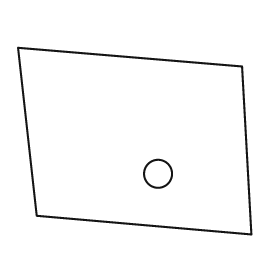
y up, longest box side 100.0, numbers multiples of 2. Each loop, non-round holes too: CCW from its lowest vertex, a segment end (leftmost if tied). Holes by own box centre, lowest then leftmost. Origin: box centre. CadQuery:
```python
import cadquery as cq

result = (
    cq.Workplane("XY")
    .moveTo(50.0, -40.0)
    .lineTo(46.0, 32.0)
    .lineTo(-50.0, 40.0)
    .lineTo(-42.0, -32.0)
    .close()
    .moveTo(10.0, -14.0)
    .circle(6.0)
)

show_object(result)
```